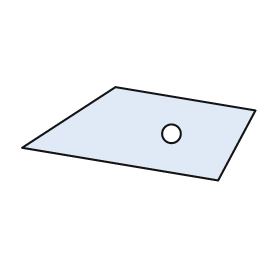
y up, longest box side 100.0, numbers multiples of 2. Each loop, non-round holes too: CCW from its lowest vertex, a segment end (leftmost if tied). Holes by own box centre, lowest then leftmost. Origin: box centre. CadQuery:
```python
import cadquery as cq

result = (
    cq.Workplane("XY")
    .moveTo(34.0, -20.0)
    .lineTo(50.0, 10.0)
    .lineTo(-10.0, 20.0)
    .lineTo(-50.0, -6.0)
    .close()
    .moveTo(14.0, 0.0)
    .circle(4.0)
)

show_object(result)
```